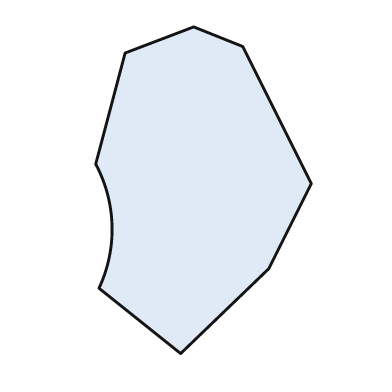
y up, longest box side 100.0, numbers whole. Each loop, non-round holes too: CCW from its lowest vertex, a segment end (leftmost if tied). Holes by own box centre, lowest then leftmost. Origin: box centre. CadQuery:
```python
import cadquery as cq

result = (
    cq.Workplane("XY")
    .moveTo(-7.0, -50.0)
    .lineTo(20.0, -24.0)
    .lineTo(33.0, 2.0)
    .lineTo(12.0, 44.0)
    .lineTo(-3.0, 50.0)
    .lineTo(-24.0, 42.0)
    .lineTo(-33.0, 8.0)
    .threePointArc((-28.0, -11.0), (-32.0, -30.0))
    .close()
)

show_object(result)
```